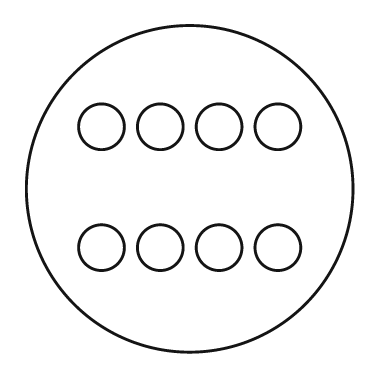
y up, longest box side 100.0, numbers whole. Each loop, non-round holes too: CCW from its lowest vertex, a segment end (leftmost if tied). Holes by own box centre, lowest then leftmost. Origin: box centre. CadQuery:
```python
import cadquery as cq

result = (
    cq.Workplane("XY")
    .moveTo(0.0, 0.0)
    .circle(50.0)
    .moveTo(-27.0, -18.0)
    .circle(7.0)
    .moveTo(-9.0, -18.0)
    .circle(7.0)
    .moveTo(9.0, -18.0)
    .circle(7.0)
    .moveTo(27.0, -18.0)
    .circle(7.0)
    .moveTo(-27.0, 19.0)
    .circle(7.0)
    .moveTo(-9.0, 19.0)
    .circle(7.0)
    .moveTo(9.0, 19.0)
    .circle(7.0)
    .moveTo(27.0, 19.0)
    .circle(7.0)
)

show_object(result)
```